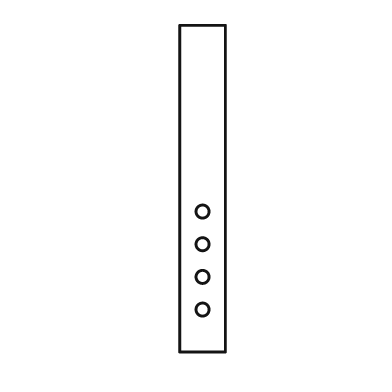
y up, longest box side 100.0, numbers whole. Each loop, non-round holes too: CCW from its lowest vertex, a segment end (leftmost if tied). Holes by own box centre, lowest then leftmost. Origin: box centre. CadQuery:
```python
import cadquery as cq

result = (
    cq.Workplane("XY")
    .moveTo(-7.0, -50.0)
    .lineTo(7.0, -50.0)
    .lineTo(7.0, 50.0)
    .lineTo(-7.0, 50.0)
    .close()
    .moveTo(0.0, -37.0)
    .circle(2.0)
    .moveTo(0.0, -27.0)
    .circle(2.0)
    .moveTo(0.0, -17.0)
    .circle(2.0)
    .moveTo(0.0, -7.0)
    .circle(2.0)
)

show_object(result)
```